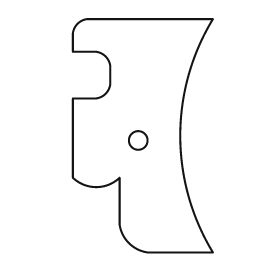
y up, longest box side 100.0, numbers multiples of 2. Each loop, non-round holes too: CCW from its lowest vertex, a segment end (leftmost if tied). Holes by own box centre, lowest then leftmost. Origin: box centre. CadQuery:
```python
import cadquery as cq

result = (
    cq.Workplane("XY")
    .moveTo(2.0, -50.0)
    .lineTo(30.0, -50.0)
    .threePointArc((16.0, 0.0), (30.0, 50.0))
    .lineTo(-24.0, 50.0)
    .threePointArc((-28.0, 48.0), (-30.0, 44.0))
    .lineTo(-30.0, 36.0)
    .lineTo(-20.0, 36.0)
    .threePointArc((-16.0, 34.0), (-14.0, 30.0))
    .lineTo(-14.0, 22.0)
    .threePointArc((-16.0, 18.0), (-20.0, 16.0))
    .lineTo(-30.0, 16.0)
    .lineTo(-30.0, -18.0)
    .threePointArc((-20.0, -22.0), (-10.0, -18.0))
    .lineTo(-10.0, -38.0)
    .threePointArc((-6.0, -46.0), (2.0, -50.0))
    .close()
    .moveTo(-2.0, -2.0)
    .circle(4.0)
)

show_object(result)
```